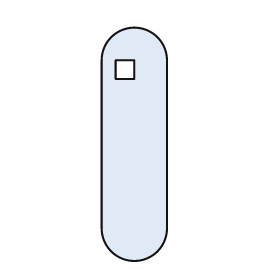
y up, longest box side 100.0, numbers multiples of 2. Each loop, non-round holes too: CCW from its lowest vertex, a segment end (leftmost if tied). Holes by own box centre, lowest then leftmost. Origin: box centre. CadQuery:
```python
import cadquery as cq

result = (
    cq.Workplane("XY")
    .moveTo(-14.0, -36.0)
    .threePointArc((0.0, -50.0), (14.0, -36.0))
    .lineTo(14.0, 36.0)
    .threePointArc((0.0, 50.0), (-14.0, 36.0))
    .close()
    .moveTo(-8.0, 28.0)
    .lineTo(0.0, 28.0)
    .lineTo(0.0, 36.0)
    .lineTo(-8.0, 36.0)
    .close()
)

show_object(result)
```